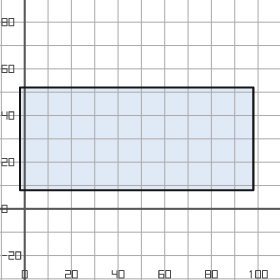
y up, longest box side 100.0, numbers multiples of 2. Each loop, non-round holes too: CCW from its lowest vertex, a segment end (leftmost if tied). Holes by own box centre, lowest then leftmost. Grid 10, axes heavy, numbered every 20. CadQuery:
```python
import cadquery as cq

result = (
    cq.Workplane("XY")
    .moveTo(-2.0, 8.0)
    .lineTo(98.0, 8.0)
    .lineTo(98.0, 52.0)
    .lineTo(-2.0, 52.0)
    .close()
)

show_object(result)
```